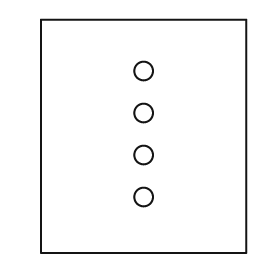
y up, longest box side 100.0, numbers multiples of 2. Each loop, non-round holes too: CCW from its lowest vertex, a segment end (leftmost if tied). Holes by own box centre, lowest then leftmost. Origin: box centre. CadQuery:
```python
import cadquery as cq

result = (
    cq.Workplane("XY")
    .moveTo(-44.0, -50.0)
    .lineTo(44.0, -50.0)
    .lineTo(44.0, 50.0)
    .lineTo(-44.0, 50.0)
    .close()
    .moveTo(0.0, -26.0)
    .circle(4.0)
    .moveTo(0.0, -8.0)
    .circle(4.0)
    .moveTo(0.0, 10.0)
    .circle(4.0)
    .moveTo(0.0, 28.0)
    .circle(4.0)
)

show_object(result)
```